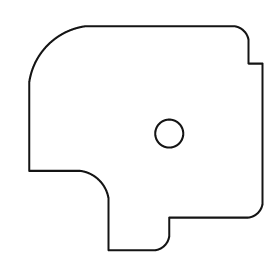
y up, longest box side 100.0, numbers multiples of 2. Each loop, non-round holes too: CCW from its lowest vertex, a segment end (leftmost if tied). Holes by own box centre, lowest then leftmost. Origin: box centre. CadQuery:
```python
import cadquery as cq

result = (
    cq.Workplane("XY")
    .moveTo(-16.0, -48.0)
    .lineTo(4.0, -48.0)
    .threePointArc((8.0, -46.0), (10.0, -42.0))
    .lineTo(10.0, -34.0)
    .lineTo(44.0, -34.0)
    .threePointArc((48.0, -32.0), (50.0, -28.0))
    .lineTo(50.0, 32.0)
    .lineTo(44.0, 32.0)
    .lineTo(44.0, 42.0)
    .threePointArc((42.0, 46.0), (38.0, 48.0))
    .lineTo(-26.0, 48.0)
    .threePointArc((-42.0, 40.0), (-50.0, 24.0))
    .lineTo(-50.0, -14.0)
    .lineTo(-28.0, -14.0)
    .threePointArc((-20.0, -18.0), (-16.0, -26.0))
    .close()
    .moveTo(10.0, 2.0)
    .circle(6.0)
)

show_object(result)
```